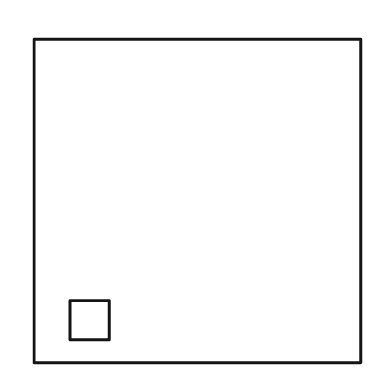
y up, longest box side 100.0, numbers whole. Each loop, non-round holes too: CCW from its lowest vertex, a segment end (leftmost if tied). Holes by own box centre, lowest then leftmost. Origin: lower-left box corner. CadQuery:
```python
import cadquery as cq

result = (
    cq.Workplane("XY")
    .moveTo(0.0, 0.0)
    .lineTo(100.0, 0.0)
    .lineTo(100.0, 99.0)
    .lineTo(0.0, 99.0)
    .close()
    .moveTo(11.0, 7.0)
    .lineTo(23.0, 7.0)
    .lineTo(23.0, 19.0)
    .lineTo(11.0, 19.0)
    .close()
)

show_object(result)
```